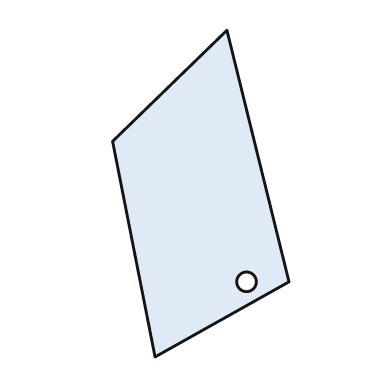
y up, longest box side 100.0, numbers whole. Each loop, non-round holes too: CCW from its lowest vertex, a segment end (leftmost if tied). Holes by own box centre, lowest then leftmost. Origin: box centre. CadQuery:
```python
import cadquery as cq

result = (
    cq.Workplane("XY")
    .moveTo(-14.0, -50.0)
    .lineTo(27.0, -27.0)
    .lineTo(8.0, 50.0)
    .lineTo(-27.0, 16.0)
    .close()
    .moveTo(14.0, -27.0)
    .circle(3.0)
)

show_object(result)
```